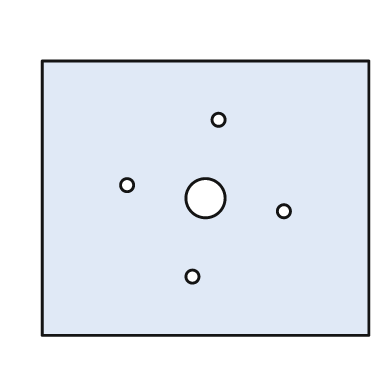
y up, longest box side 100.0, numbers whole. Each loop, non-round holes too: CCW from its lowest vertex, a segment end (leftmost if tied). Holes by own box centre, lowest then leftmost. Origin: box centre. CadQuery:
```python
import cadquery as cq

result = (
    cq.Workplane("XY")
    .moveTo(-50.0, -42.0)
    .lineTo(50.0, -42.0)
    .lineTo(50.0, 42.0)
    .lineTo(-50.0, 42.0)
    .close()
    .moveTo(-4.0, -24.0)
    .circle(2.0)
    .moveTo(24.0, -4.0)
    .circle(2.0)
    .moveTo(0.0, 0.0)
    .circle(6.0)
    .moveTo(-24.0, 4.0)
    .circle(2.0)
    .moveTo(4.0, 24.0)
    .circle(2.0)
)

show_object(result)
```